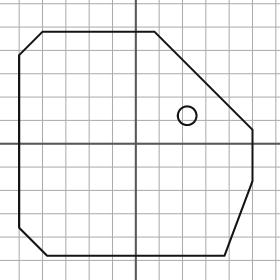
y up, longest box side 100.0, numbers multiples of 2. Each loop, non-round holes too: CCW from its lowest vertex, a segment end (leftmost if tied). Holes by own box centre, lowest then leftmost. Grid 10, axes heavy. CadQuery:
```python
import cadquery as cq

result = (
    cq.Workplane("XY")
    .moveTo(-38.0, -48.0)
    .lineTo(38.0, -48.0)
    .lineTo(50.0, -16.0)
    .lineTo(50.0, 6.0)
    .lineTo(8.0, 48.0)
    .lineTo(-40.0, 48.0)
    .lineTo(-50.0, 38.0)
    .lineTo(-50.0, -36.0)
    .close()
    .moveTo(22.0, 12.0)
    .circle(4.0)
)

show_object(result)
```